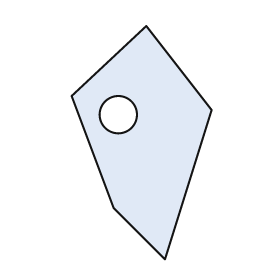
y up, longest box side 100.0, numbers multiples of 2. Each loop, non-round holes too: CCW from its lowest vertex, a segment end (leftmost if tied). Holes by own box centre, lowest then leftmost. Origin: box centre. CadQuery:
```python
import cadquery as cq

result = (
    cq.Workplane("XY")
    .moveTo(10.0, -50.0)
    .lineTo(30.0, 14.0)
    .lineTo(2.0, 50.0)
    .lineTo(-30.0, 20.0)
    .lineTo(-12.0, -28.0)
    .close()
    .moveTo(-10.0, 12.0)
    .circle(8.0)
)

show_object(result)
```